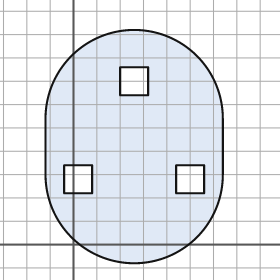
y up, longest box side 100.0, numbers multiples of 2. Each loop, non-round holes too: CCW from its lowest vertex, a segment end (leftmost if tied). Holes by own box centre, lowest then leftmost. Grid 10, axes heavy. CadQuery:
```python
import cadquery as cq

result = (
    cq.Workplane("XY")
    .moveTo(-12.0, 30.0)
    .threePointArc((26.0, -8.0), (64.0, 30.0))
    .lineTo(64.0, 54.0)
    .threePointArc((26.0, 92.0), (-12.0, 54.0))
    .close()
    .moveTo(-4.0, 22.0)
    .lineTo(8.0, 22.0)
    .lineTo(8.0, 34.0)
    .lineTo(-4.0, 34.0)
    .close()
    .moveTo(44.0, 22.0)
    .lineTo(56.0, 22.0)
    .lineTo(56.0, 34.0)
    .lineTo(44.0, 34.0)
    .close()
    .moveTo(20.0, 64.0)
    .lineTo(32.0, 64.0)
    .lineTo(32.0, 76.0)
    .lineTo(20.0, 76.0)
    .close()
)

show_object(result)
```